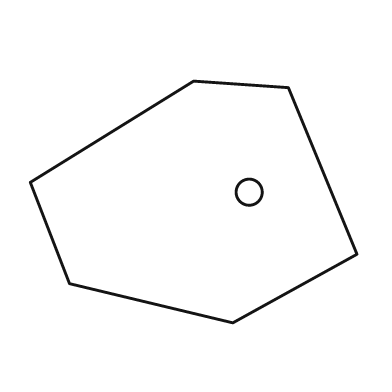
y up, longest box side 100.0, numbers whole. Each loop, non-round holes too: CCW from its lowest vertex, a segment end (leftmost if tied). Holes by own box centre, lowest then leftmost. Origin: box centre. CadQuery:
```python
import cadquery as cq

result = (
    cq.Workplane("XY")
    .moveTo(12.0, -37.0)
    .lineTo(50.0, -16.0)
    .lineTo(29.0, 35.0)
    .lineTo(0.0, 37.0)
    .lineTo(-50.0, 6.0)
    .lineTo(-38.0, -25.0)
    .close()
    .moveTo(17.0, 3.0)
    .circle(4.0)
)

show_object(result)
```